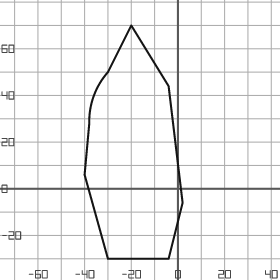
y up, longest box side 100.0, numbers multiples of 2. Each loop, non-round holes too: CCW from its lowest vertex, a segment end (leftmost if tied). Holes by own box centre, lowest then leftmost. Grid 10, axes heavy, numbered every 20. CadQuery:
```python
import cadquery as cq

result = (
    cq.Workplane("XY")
    .moveTo(-30.0, -30.0)
    .lineTo(-4.0, -30.0)
    .lineTo(2.0, -6.0)
    .lineTo(-4.0, 44.0)
    .lineTo(-20.0, 70.0)
    .lineTo(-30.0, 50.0)
    .threePointArc((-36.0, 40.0), (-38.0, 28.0))
    .lineTo(-40.0, 6.0)
    .close()
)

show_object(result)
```